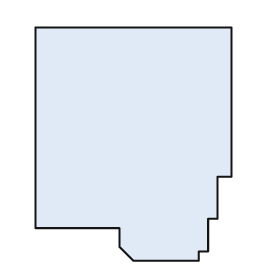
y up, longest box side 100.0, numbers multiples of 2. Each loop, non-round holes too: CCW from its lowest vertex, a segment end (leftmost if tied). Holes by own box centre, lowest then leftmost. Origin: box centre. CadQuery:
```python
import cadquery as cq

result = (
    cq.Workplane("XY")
    .moveTo(0.0, -50.0)
    .lineTo(28.0, -50.0)
    .lineTo(28.0, -46.0)
    .lineTo(32.0, -46.0)
    .lineTo(32.0, -32.0)
    .lineTo(36.0, -32.0)
    .lineTo(36.0, -14.0)
    .lineTo(42.0, -14.0)
    .lineTo(42.0, 50.0)
    .lineTo(-42.0, 50.0)
    .lineTo(-42.0, -36.0)
    .lineTo(-6.0, -36.0)
    .lineTo(-6.0, -44.0)
    .close()
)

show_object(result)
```